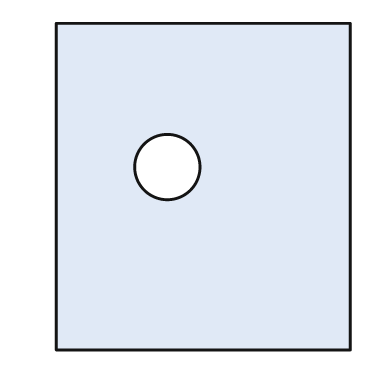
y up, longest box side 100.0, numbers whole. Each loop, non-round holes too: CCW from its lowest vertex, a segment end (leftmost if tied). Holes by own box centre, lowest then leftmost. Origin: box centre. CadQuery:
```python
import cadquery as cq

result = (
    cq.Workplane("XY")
    .moveTo(-45.0, -50.0)
    .lineTo(45.0, -50.0)
    .lineTo(45.0, 50.0)
    .lineTo(-45.0, 50.0)
    .close()
    .moveTo(-11.0, 6.0)
    .circle(10.0)
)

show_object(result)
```